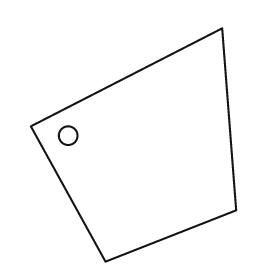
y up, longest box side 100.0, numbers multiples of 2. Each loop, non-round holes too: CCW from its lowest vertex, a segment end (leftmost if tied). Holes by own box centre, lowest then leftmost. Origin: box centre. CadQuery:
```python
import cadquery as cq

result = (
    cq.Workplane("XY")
    .moveTo(-12.0, -50.0)
    .lineTo(44.0, -28.0)
    .lineTo(38.0, 50.0)
    .lineTo(-44.0, 8.0)
    .close()
    .moveTo(-28.0, 4.0)
    .circle(4.0)
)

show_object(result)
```